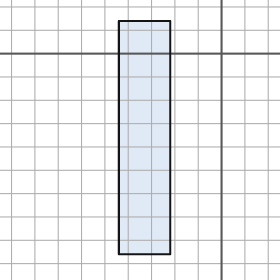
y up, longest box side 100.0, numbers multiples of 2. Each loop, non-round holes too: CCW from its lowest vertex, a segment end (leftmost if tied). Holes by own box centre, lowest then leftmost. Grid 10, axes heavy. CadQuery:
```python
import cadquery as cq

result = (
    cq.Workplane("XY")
    .moveTo(-44.0, -86.0)
    .lineTo(-22.0, -86.0)
    .lineTo(-22.0, 14.0)
    .lineTo(-44.0, 14.0)
    .close()
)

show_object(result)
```